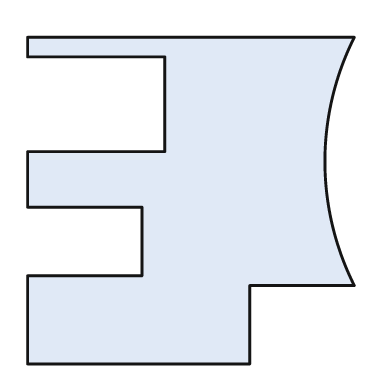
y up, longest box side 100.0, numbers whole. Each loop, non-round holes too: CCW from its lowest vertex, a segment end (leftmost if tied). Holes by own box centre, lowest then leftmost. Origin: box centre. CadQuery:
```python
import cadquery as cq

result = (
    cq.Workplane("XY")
    .moveTo(-50.0, -50.0)
    .lineTo(18.0, -50.0)
    .lineTo(18.0, -26.0)
    .lineTo(50.0, -26.0)
    .threePointArc((41.0, 12.0), (50.0, 50.0))
    .lineTo(-50.0, 50.0)
    .lineTo(-50.0, 44.0)
    .lineTo(-8.0, 44.0)
    .lineTo(-8.0, 15.0)
    .lineTo(-50.0, 15.0)
    .lineTo(-50.0, -2.0)
    .lineTo(-15.0, -2.0)
    .lineTo(-15.0, -23.0)
    .lineTo(-50.0, -23.0)
    .close()
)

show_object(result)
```